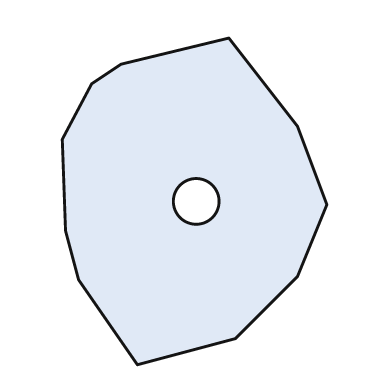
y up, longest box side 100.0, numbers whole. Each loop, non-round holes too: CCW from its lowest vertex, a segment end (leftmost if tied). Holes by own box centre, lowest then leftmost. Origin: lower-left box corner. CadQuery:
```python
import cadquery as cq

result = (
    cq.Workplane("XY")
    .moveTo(23.0, 0.0)
    .lineTo(53.0, 8.0)
    .lineTo(72.0, 27.0)
    .lineTo(81.0, 49.0)
    .lineTo(72.0, 73.0)
    .lineTo(51.0, 100.0)
    .lineTo(18.0, 92.0)
    .lineTo(9.0, 86.0)
    .lineTo(0.0, 69.0)
    .lineTo(1.0, 41.0)
    .lineTo(5.0, 26.0)
    .close()
    .moveTo(41.0, 50.0)
    .circle(7.0)
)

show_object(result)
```